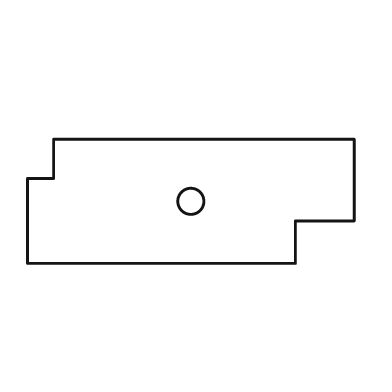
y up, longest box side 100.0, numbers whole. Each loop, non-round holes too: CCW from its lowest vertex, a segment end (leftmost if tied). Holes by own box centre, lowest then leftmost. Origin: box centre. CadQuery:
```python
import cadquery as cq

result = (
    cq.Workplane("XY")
    .moveTo(-50.0, -19.0)
    .lineTo(32.0, -19.0)
    .lineTo(32.0, -6.0)
    .lineTo(50.0, -6.0)
    .lineTo(50.0, 19.0)
    .lineTo(-42.0, 19.0)
    .lineTo(-42.0, 7.0)
    .lineTo(-50.0, 7.0)
    .close()
    .moveTo(0.0, 0.0)
    .circle(4.0)
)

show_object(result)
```